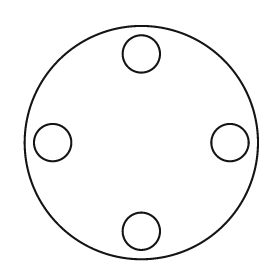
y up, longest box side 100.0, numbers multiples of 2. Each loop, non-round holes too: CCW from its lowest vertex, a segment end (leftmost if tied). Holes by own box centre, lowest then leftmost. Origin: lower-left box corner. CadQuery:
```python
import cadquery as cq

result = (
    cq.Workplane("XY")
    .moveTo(50.0, 50.0)
    .circle(50.0)
    .moveTo(50.0, 12.0)
    .circle(8.0)
    .moveTo(12.0, 50.0)
    .circle(8.0)
    .moveTo(88.0, 50.0)
    .circle(8.0)
    .moveTo(50.0, 88.0)
    .circle(8.0)
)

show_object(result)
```